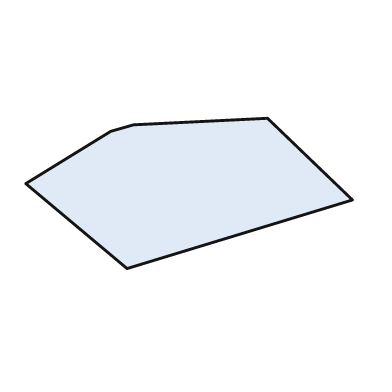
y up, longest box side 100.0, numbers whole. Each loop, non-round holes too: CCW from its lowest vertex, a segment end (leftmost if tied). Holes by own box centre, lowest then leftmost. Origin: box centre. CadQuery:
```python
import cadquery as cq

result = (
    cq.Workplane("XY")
    .moveTo(-19.0, -23.0)
    .lineTo(50.0, -2.0)
    .lineTo(24.0, 23.0)
    .lineTo(-17.0, 21.0)
    .lineTo(-24.0, 19.0)
    .lineTo(-50.0, 3.0)
    .close()
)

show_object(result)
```